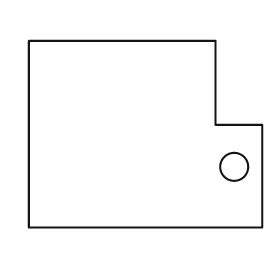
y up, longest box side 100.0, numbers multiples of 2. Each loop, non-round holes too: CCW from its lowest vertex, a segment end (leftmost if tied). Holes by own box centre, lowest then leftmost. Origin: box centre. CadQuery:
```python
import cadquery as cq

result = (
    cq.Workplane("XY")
    .moveTo(-50.0, -40.0)
    .lineTo(50.0, -40.0)
    .lineTo(50.0, 4.0)
    .lineTo(30.0, 4.0)
    .lineTo(30.0, 40.0)
    .lineTo(-50.0, 40.0)
    .close()
    .moveTo(38.0, -14.0)
    .circle(6.0)
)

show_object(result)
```